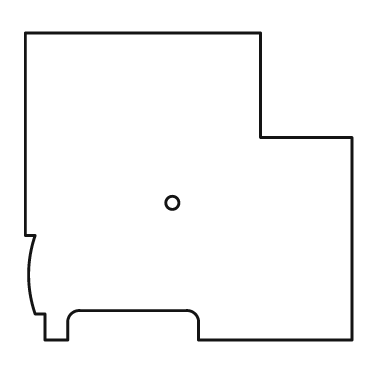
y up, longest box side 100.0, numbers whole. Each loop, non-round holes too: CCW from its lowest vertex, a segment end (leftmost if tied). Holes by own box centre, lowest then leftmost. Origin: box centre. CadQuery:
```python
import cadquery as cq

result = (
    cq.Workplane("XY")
    .moveTo(-44.0, -47.0)
    .lineTo(-37.0, -47.0)
    .lineTo(-37.0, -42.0)
    .threePointArc((-36.0, -39.0), (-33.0, -38.0))
    .lineTo(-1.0, -38.0)
    .threePointArc((2.0, -39.0), (3.0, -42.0))
    .lineTo(3.0, -47.0)
    .lineTo(50.0, -47.0)
    .lineTo(50.0, 15.0)
    .lineTo(22.0, 15.0)
    .lineTo(22.0, 47.0)
    .lineTo(-50.0, 47.0)
    .lineTo(-50.0, -15.0)
    .lineTo(-47.0, -15.0)
    .threePointArc((-49.0, -27.0), (-47.0, -39.0))
    .lineTo(-44.0, -39.0)
    .close()
    .moveTo(-5.0, -5.0)
    .circle(2.0)
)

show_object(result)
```